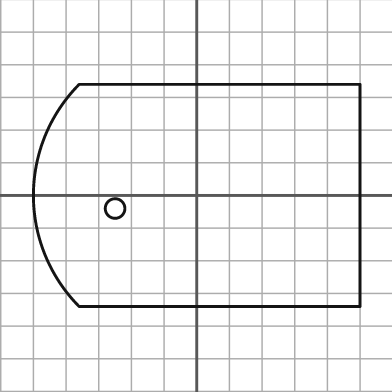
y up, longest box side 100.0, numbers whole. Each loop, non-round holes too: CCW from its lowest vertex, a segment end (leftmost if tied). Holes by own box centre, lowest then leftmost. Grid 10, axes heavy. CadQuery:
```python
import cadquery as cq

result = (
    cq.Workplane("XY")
    .moveTo(-36.0, -34.0)
    .lineTo(50.0, -34.0)
    .lineTo(50.0, 34.0)
    .lineTo(-36.0, 34.0)
    .threePointArc((-50.0, 0.0), (-36.0, -34.0))
    .close()
    .moveTo(-25.0, -4.0)
    .circle(3.0)
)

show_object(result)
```